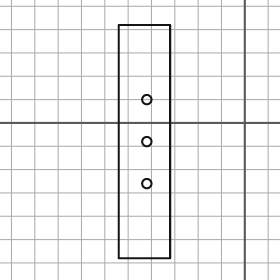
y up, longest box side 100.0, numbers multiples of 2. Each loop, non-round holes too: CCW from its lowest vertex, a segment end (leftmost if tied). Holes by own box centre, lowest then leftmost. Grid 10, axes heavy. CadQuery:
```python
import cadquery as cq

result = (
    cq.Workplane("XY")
    .moveTo(-54.0, -58.0)
    .lineTo(-32.0, -58.0)
    .lineTo(-32.0, 42.0)
    .lineTo(-54.0, 42.0)
    .close()
    .moveTo(-42.0, -26.0)
    .circle(2.0)
    .moveTo(-42.0, -8.0)
    .circle(2.0)
    .moveTo(-42.0, 10.0)
    .circle(2.0)
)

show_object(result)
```